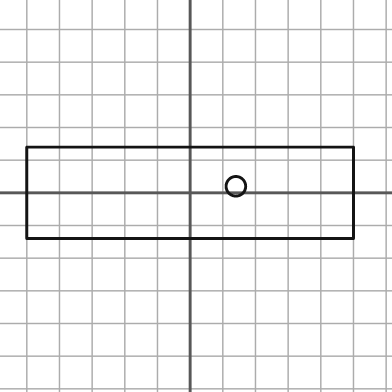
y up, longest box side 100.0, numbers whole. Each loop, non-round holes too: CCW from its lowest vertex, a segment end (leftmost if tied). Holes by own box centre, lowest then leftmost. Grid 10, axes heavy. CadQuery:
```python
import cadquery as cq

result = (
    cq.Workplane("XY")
    .moveTo(-50.0, -14.0)
    .lineTo(50.0, -14.0)
    .lineTo(50.0, 14.0)
    .lineTo(-50.0, 14.0)
    .close()
    .moveTo(14.0, 2.0)
    .circle(3.0)
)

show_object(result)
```